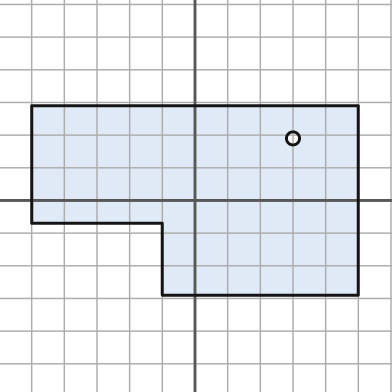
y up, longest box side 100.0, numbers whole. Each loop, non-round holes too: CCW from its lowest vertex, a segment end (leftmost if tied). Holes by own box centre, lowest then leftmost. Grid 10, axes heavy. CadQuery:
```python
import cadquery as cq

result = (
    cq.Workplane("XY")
    .moveTo(-10.0, -29.0)
    .lineTo(50.0, -29.0)
    .lineTo(50.0, 29.0)
    .lineTo(-50.0, 29.0)
    .lineTo(-50.0, -7.0)
    .lineTo(-10.0, -7.0)
    .close()
    .moveTo(30.0, 19.0)
    .circle(2.0)
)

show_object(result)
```